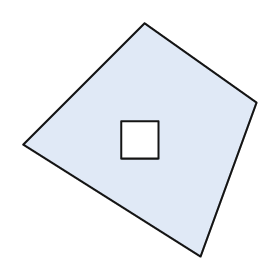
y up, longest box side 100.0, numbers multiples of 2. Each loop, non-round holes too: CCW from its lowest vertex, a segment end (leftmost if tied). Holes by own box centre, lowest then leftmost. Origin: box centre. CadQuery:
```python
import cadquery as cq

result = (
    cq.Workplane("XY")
    .moveTo(26.0, -50.0)
    .lineTo(50.0, 16.0)
    .lineTo(2.0, 50.0)
    .lineTo(-50.0, -2.0)
    .close()
    .moveTo(-8.0, -8.0)
    .lineTo(8.0, -8.0)
    .lineTo(8.0, 8.0)
    .lineTo(-8.0, 8.0)
    .close()
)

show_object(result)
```